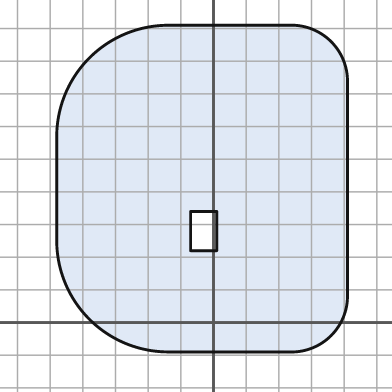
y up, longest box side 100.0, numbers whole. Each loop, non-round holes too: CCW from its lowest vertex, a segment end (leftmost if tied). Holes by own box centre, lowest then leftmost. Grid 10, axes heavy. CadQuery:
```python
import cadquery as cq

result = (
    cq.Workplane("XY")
    .moveTo(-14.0, -9.0)
    .lineTo(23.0, -9.0)
    .threePointArc((36.0, -4.0), (41.0, 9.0))
    .lineTo(41.0, 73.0)
    .threePointArc((36.0, 86.0), (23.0, 91.0))
    .lineTo(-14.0, 91.0)
    .threePointArc((-38.0, 81.0), (-48.0, 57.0))
    .lineTo(-48.0, 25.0)
    .threePointArc((-38.0, 1.0), (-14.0, -9.0))
    .close()
    .moveTo(-7.0, 22.0)
    .lineTo(1.0, 22.0)
    .lineTo(1.0, 34.0)
    .lineTo(-7.0, 34.0)
    .close()
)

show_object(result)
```